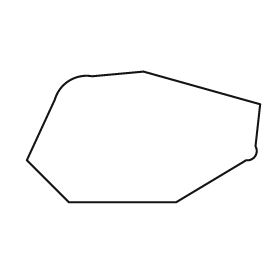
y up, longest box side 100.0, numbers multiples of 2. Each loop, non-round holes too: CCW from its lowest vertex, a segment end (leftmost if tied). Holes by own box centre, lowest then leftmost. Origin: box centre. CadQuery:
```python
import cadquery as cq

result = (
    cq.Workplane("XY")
    .moveTo(-32.0, -28.0)
    .lineTo(14.0, -28.0)
    .lineTo(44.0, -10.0)
    .threePointArc((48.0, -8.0), (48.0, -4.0))
    .lineTo(50.0, 14.0)
    .lineTo(0.0, 28.0)
    .lineTo(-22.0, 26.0)
    .threePointArc((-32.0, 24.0), (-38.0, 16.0))
    .lineTo(-50.0, -10.0)
    .close()
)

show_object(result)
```